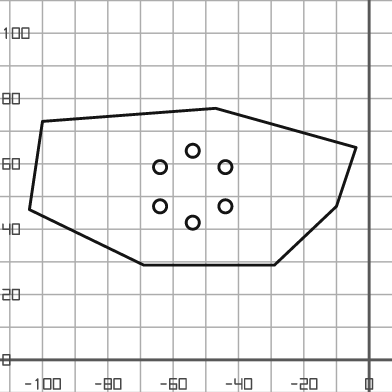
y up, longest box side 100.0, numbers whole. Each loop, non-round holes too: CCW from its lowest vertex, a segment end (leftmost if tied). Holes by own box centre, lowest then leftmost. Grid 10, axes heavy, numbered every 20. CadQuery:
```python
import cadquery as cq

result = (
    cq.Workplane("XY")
    .moveTo(-69.0, 29.0)
    .lineTo(-29.0, 29.0)
    .lineTo(-10.0, 47.0)
    .lineTo(-4.0, 65.0)
    .lineTo(-47.0, 77.0)
    .lineTo(-100.0, 73.0)
    .lineTo(-104.0, 46.0)
    .close()
    .moveTo(-54.0, 42.0)
    .circle(2.0)
    .moveTo(-64.0, 47.0)
    .circle(2.0)
    .moveTo(-44.0, 47.0)
    .circle(2.0)
    .moveTo(-64.0, 59.0)
    .circle(2.0)
    .moveTo(-44.0, 59.0)
    .circle(2.0)
    .moveTo(-54.0, 64.0)
    .circle(2.0)
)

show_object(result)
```